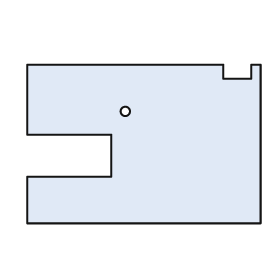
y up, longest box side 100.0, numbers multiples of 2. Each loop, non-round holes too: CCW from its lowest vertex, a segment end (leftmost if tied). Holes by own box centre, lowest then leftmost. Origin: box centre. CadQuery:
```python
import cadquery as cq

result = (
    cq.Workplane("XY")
    .moveTo(-50.0, -34.0)
    .lineTo(50.0, -34.0)
    .lineTo(50.0, 34.0)
    .lineTo(46.0, 34.0)
    .lineTo(46.0, 28.0)
    .lineTo(34.0, 28.0)
    .lineTo(34.0, 34.0)
    .lineTo(-50.0, 34.0)
    .lineTo(-50.0, 4.0)
    .lineTo(-14.0, 4.0)
    .lineTo(-14.0, -14.0)
    .lineTo(-50.0, -14.0)
    .close()
    .moveTo(-8.0, 14.0)
    .circle(2.0)
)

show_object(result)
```